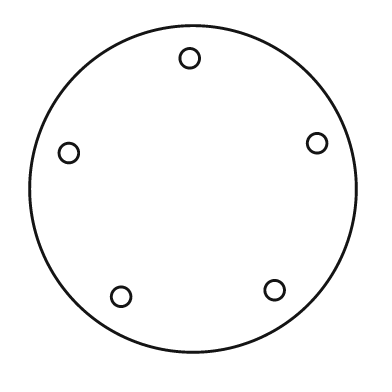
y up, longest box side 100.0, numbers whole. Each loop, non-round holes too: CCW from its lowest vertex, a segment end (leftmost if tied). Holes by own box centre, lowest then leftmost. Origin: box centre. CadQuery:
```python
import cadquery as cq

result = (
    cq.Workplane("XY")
    .moveTo(0.0, 0.0)
    .circle(50.0)
    .moveTo(-22.0, -33.0)
    .circle(3.0)
    .moveTo(25.0, -31.0)
    .circle(3.0)
    .moveTo(-38.0, 11.0)
    .circle(3.0)
    .moveTo(38.0, 14.0)
    .circle(3.0)
    .moveTo(-1.0, 40.0)
    .circle(3.0)
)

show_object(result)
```